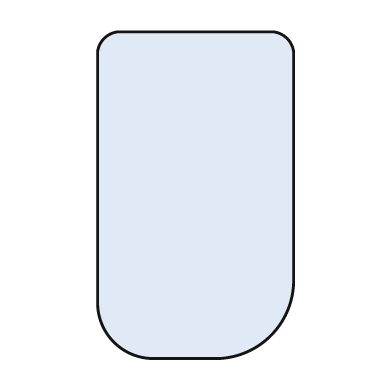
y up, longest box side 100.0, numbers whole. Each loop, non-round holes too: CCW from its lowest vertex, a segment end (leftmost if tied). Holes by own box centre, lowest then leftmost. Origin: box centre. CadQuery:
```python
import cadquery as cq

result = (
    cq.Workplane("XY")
    .moveTo(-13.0, -50.0)
    .lineTo(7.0, -50.0)
    .threePointArc((23.0, -43.0), (30.0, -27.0))
    .lineTo(30.0, 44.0)
    .threePointArc((28.0, 48.0), (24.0, 50.0))
    .lineTo(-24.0, 50.0)
    .threePointArc((-28.0, 48.0), (-30.0, 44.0))
    .lineTo(-30.0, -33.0)
    .threePointArc((-25.0, -45.0), (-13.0, -50.0))
    .close()
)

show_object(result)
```